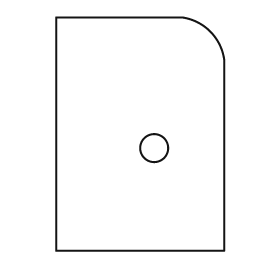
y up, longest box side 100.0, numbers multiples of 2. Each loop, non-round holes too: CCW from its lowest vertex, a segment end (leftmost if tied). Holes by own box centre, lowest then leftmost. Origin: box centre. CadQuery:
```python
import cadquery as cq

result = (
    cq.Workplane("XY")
    .moveTo(-36.0, -50.0)
    .lineTo(36.0, -50.0)
    .lineTo(36.0, 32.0)
    .threePointArc((30.0, 44.0), (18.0, 50.0))
    .lineTo(-36.0, 50.0)
    .close()
    .moveTo(6.0, -6.0)
    .circle(6.0)
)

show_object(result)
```